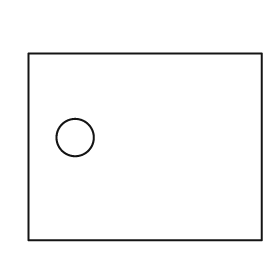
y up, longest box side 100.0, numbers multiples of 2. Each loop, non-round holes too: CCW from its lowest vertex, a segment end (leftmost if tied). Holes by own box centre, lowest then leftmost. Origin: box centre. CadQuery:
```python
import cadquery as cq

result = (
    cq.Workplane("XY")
    .moveTo(-50.0, -40.0)
    .lineTo(50.0, -40.0)
    .lineTo(50.0, 40.0)
    .lineTo(-50.0, 40.0)
    .close()
    .moveTo(-30.0, 4.0)
    .circle(8.0)
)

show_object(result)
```